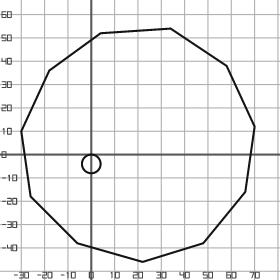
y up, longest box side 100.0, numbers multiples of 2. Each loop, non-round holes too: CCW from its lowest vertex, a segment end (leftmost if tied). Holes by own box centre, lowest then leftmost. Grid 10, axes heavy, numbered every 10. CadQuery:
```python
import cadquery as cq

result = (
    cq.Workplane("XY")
    .moveTo(22.0, -46.0)
    .lineTo(48.0, -38.0)
    .lineTo(66.0, -16.0)
    .lineTo(70.0, 12.0)
    .lineTo(58.0, 38.0)
    .lineTo(34.0, 54.0)
    .lineTo(4.0, 52.0)
    .lineTo(-18.0, 36.0)
    .lineTo(-30.0, 10.0)
    .lineTo(-26.0, -18.0)
    .lineTo(-6.0, -38.0)
    .close()
    .moveTo(0.0, -4.0)
    .circle(4.0)
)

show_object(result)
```